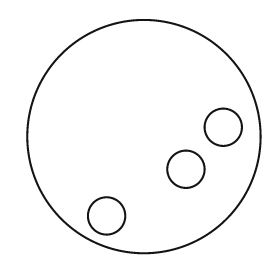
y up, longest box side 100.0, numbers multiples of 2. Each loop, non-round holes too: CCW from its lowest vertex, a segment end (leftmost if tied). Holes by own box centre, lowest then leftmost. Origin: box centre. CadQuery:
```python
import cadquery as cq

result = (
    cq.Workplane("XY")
    .moveTo(0.0, 0.0)
    .circle(50.0)
    .moveTo(-16.0, -34.0)
    .circle(8.0)
    .moveTo(18.0, -14.0)
    .circle(8.0)
    .moveTo(34.0, 4.0)
    .circle(8.0)
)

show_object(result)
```